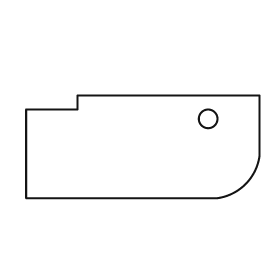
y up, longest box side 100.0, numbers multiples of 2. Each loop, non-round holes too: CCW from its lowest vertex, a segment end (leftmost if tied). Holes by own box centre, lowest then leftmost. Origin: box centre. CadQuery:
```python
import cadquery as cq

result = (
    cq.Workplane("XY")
    .moveTo(-50.0, -22.0)
    .lineTo(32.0, -22.0)
    .threePointArc((44.0, -16.0), (50.0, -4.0))
    .lineTo(50.0, 22.0)
    .lineTo(-28.0, 22.0)
    .lineTo(-28.0, 16.0)
    .lineTo(-50.0, 16.0)
    .close()
    .moveTo(28.0, 12.0)
    .circle(4.0)
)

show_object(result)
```